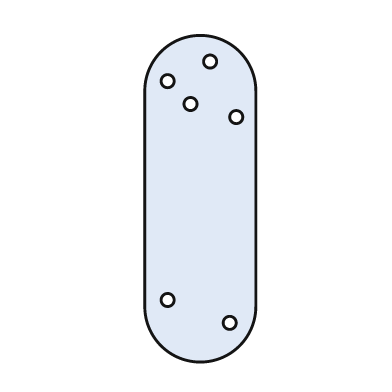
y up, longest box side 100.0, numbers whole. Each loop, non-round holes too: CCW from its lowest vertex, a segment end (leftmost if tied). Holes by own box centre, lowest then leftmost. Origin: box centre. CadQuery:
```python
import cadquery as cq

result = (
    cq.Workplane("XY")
    .moveTo(-17.0, -33.0)
    .threePointArc((0.0, -50.0), (17.0, -33.0))
    .lineTo(17.0, 33.0)
    .threePointArc((0.0, 50.0), (-17.0, 33.0))
    .close()
    .moveTo(9.0, -38.0)
    .circle(2.0)
    .moveTo(-10.0, -31.0)
    .circle(2.0)
    .moveTo(11.0, 25.0)
    .circle(2.0)
    .moveTo(-3.0, 29.0)
    .circle(2.0)
    .moveTo(-10.0, 36.0)
    .circle(2.0)
    .moveTo(3.0, 42.0)
    .circle(2.0)
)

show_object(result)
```